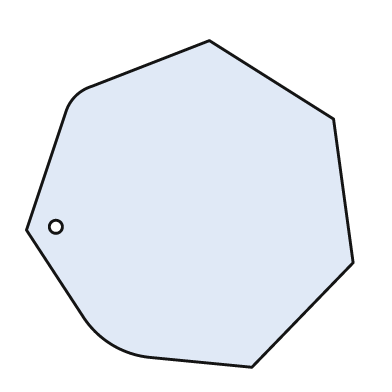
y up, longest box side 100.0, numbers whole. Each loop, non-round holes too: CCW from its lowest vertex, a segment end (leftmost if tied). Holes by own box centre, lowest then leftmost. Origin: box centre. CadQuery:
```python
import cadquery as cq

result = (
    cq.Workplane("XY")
    .moveTo(19.0, -50.0)
    .lineTo(50.0, -18.0)
    .lineTo(44.0, 26.0)
    .lineTo(6.0, 50.0)
    .lineTo(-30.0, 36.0)
    .threePointArc((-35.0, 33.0), (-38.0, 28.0))
    .lineTo(-50.0, -8.0)
    .lineTo(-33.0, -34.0)
    .threePointArc((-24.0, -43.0), (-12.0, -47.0))
    .close()
    .moveTo(-41.0, -7.0)
    .circle(2.0)
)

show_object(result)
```